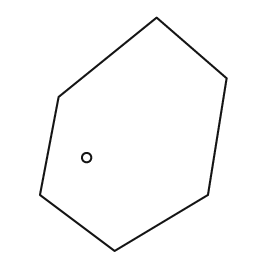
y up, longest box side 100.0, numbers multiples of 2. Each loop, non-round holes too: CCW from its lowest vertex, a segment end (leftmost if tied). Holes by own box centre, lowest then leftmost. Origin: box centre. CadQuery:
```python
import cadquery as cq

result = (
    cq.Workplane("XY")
    .moveTo(-8.0, -50.0)
    .lineTo(32.0, -26.0)
    .lineTo(40.0, 24.0)
    .lineTo(10.0, 50.0)
    .lineTo(-32.0, 16.0)
    .lineTo(-40.0, -26.0)
    .close()
    .moveTo(-20.0, -10.0)
    .circle(2.0)
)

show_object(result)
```